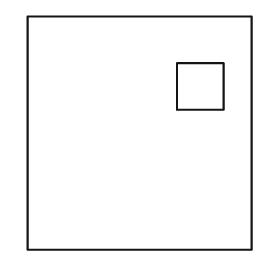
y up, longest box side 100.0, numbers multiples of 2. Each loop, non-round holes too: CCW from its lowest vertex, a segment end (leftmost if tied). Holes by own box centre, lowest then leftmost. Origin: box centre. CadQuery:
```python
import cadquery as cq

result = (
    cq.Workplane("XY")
    .moveTo(-48.0, -50.0)
    .lineTo(48.0, -50.0)
    .lineTo(48.0, 50.0)
    .lineTo(-48.0, 50.0)
    .close()
    .moveTo(16.0, 10.0)
    .lineTo(36.0, 10.0)
    .lineTo(36.0, 30.0)
    .lineTo(16.0, 30.0)
    .close()
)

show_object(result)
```